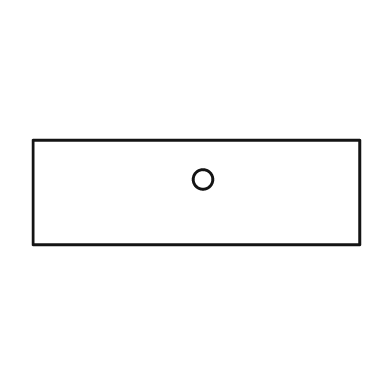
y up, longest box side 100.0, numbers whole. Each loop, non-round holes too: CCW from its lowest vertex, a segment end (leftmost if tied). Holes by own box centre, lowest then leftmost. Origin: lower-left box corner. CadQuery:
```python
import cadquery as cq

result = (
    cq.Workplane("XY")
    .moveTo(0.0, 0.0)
    .lineTo(100.0, 0.0)
    .lineTo(100.0, 32.0)
    .lineTo(0.0, 32.0)
    .close()
    .moveTo(52.0, 20.0)
    .circle(3.0)
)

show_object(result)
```